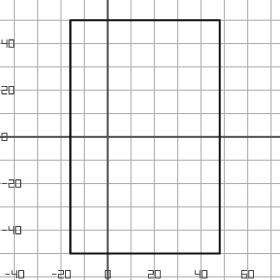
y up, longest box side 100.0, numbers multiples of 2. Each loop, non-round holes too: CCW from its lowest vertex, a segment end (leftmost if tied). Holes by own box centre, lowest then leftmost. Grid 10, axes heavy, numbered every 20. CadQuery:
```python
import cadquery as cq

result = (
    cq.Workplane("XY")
    .moveTo(-16.0, -50.0)
    .lineTo(48.0, -50.0)
    .lineTo(48.0, 50.0)
    .lineTo(-16.0, 50.0)
    .close()
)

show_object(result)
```